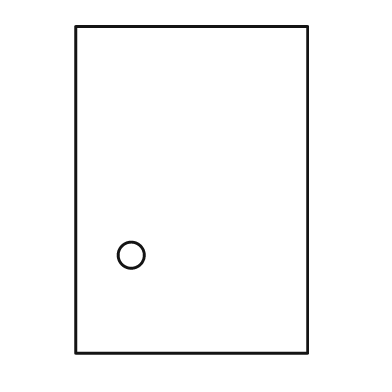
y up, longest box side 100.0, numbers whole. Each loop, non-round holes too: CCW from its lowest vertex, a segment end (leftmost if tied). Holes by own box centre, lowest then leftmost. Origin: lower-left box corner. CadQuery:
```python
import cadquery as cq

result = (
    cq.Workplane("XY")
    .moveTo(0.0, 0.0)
    .lineTo(71.0, 0.0)
    .lineTo(71.0, 100.0)
    .lineTo(0.0, 100.0)
    .close()
    .moveTo(17.0, 30.0)
    .circle(4.0)
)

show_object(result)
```